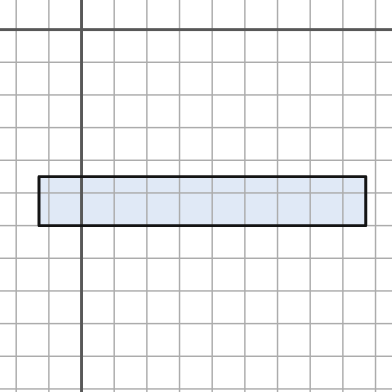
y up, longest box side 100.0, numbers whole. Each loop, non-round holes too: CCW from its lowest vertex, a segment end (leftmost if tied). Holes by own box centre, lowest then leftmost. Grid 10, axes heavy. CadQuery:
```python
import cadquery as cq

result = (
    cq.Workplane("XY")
    .moveTo(-13.0, -60.0)
    .lineTo(87.0, -60.0)
    .lineTo(87.0, -45.0)
    .lineTo(-13.0, -45.0)
    .close()
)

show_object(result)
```